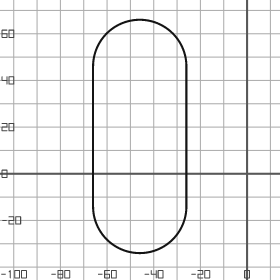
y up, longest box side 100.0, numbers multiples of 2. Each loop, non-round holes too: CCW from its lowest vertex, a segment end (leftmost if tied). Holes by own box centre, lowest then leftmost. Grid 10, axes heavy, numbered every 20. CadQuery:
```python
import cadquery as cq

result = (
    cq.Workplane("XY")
    .moveTo(-66.0, -14.0)
    .threePointArc((-46.0, -34.0), (-26.0, -14.0))
    .lineTo(-26.0, 46.0)
    .threePointArc((-46.0, 66.0), (-66.0, 46.0))
    .close()
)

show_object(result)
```